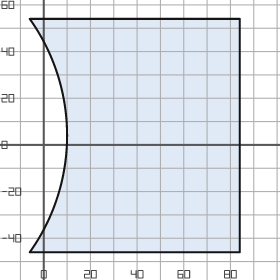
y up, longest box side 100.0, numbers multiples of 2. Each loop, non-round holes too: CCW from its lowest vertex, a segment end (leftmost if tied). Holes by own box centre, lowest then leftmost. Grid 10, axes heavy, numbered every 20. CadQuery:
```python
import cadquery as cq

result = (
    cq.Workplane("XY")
    .moveTo(-6.0, -46.0)
    .lineTo(84.0, -46.0)
    .lineTo(84.0, 54.0)
    .lineTo(-6.0, 54.0)
    .threePointArc((10.0, 4.0), (-6.0, -46.0))
    .close()
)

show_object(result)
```